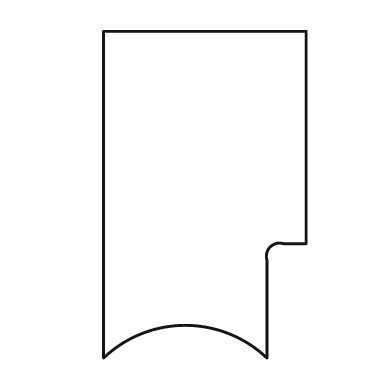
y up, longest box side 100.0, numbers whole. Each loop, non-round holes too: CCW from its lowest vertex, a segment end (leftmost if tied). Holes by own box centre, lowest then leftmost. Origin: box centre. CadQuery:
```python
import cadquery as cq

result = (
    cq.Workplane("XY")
    .moveTo(-31.0, -50.0)
    .threePointArc((-6.0, -40.0), (19.0, -50.0))
    .lineTo(19.0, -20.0)
    .threePointArc((20.0, -16.0), (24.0, -15.0))
    .lineTo(31.0, -15.0)
    .lineTo(31.0, 50.0)
    .lineTo(-31.0, 50.0)
    .close()
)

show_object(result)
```